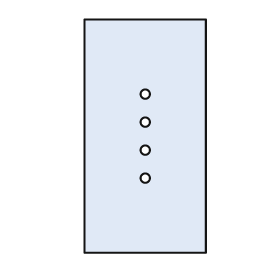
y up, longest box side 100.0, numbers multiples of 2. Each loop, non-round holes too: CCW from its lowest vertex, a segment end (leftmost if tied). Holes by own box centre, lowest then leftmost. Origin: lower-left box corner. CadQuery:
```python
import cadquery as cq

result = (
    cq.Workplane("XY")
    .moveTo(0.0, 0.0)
    .lineTo(52.0, 0.0)
    .lineTo(52.0, 100.0)
    .lineTo(0.0, 100.0)
    .close()
    .moveTo(26.0, 32.0)
    .circle(2.0)
    .moveTo(26.0, 44.0)
    .circle(2.0)
    .moveTo(26.0, 56.0)
    .circle(2.0)
    .moveTo(26.0, 68.0)
    .circle(2.0)
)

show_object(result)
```